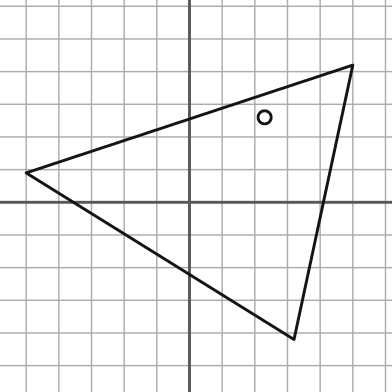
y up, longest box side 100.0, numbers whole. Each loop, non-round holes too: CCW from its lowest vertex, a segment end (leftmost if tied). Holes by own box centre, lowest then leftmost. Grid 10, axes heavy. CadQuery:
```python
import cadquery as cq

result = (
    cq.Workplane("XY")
    .moveTo(32.0, -42.0)
    .lineTo(50.0, 42.0)
    .lineTo(-50.0, 9.0)
    .close()
    .moveTo(23.0, 26.0)
    .circle(2.0)
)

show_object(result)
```